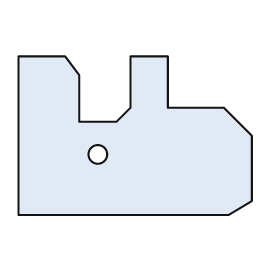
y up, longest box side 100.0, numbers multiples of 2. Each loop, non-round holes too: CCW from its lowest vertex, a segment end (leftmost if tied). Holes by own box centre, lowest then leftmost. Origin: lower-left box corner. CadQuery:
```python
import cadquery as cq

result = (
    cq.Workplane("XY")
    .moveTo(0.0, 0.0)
    .lineTo(90.0, 0.0)
    .lineTo(100.0, 6.0)
    .lineTo(100.0, 34.0)
    .lineTo(88.0, 46.0)
    .lineTo(64.0, 46.0)
    .lineTo(64.0, 68.0)
    .lineTo(48.0, 68.0)
    .lineTo(48.0, 46.0)
    .lineTo(42.0, 40.0)
    .lineTo(26.0, 40.0)
    .lineTo(26.0, 60.0)
    .lineTo(20.0, 68.0)
    .lineTo(0.0, 68.0)
    .close()
    .moveTo(34.0, 26.0)
    .circle(4.0)
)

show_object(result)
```